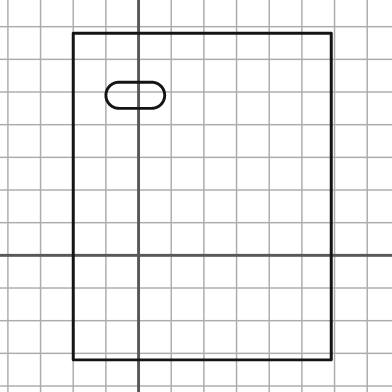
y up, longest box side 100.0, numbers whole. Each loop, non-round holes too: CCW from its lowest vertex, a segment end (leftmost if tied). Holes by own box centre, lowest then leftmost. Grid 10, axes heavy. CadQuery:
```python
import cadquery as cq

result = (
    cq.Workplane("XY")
    .moveTo(-20.0, -32.0)
    .lineTo(59.0, -32.0)
    .lineTo(59.0, 68.0)
    .lineTo(-20.0, 68.0)
    .close()
    .moveTo(-6.0, 45.0)
    .lineTo(4.0, 45.0)
    .threePointArc((8.0, 49.0), (4.0, 53.0))
    .lineTo(-6.0, 53.0)
    .threePointArc((-10.0, 49.0), (-6.0, 45.0))
    .close()
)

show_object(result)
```